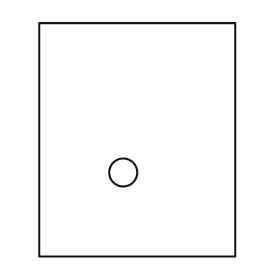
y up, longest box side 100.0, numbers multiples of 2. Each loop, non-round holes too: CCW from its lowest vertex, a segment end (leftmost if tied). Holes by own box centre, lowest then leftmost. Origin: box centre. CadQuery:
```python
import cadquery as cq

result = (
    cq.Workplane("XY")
    .moveTo(-42.0, -50.0)
    .lineTo(42.0, -50.0)
    .lineTo(42.0, 50.0)
    .lineTo(-42.0, 50.0)
    .close()
    .moveTo(-6.0, -14.0)
    .circle(6.0)
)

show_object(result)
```